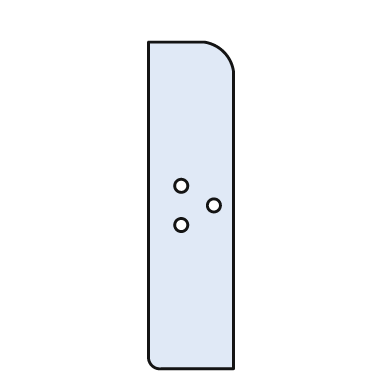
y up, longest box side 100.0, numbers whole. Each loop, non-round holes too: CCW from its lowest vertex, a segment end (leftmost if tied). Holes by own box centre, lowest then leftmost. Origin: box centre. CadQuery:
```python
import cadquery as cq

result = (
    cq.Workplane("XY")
    .moveTo(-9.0, -50.0)
    .lineTo(13.0, -50.0)
    .lineTo(13.0, 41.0)
    .threePointArc((10.0, 47.0), (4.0, 50.0))
    .lineTo(-13.0, 50.0)
    .lineTo(-13.0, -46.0)
    .threePointArc((-12.0, -49.0), (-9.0, -50.0))
    .close()
    .moveTo(-3.0, -6.0)
    .circle(2.0)
    .moveTo(7.0, 0.0)
    .circle(2.0)
    .moveTo(-3.0, 6.0)
    .circle(2.0)
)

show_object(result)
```